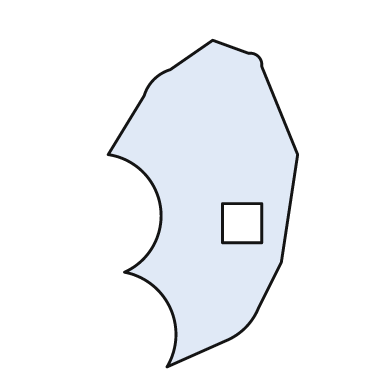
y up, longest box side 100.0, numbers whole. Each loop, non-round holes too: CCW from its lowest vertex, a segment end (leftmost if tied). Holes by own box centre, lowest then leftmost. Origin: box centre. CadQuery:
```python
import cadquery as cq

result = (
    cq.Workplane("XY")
    .moveTo(-11.0, -50.0)
    .lineTo(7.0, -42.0)
    .threePointArc((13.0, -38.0), (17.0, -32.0))
    .lineTo(24.0, -18.0)
    .lineTo(29.0, 15.0)
    .lineTo(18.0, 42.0)
    .threePointArc((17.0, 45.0), (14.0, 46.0))
    .lineTo(3.0, 50.0)
    .lineTo(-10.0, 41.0)
    .threePointArc((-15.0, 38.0), (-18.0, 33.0))
    .lineTo(-29.0, 15.0)
    .threePointArc((-13.0, -1.0), (-24.0, -21.0))
    .threePointArc((-10.0, -32.0), (-11.0, -50.0))
    .close()
    .moveTo(6.0, -12.0)
    .lineTo(18.0, -12.0)
    .lineTo(18.0, 0.0)
    .lineTo(6.0, 0.0)
    .close()
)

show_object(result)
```